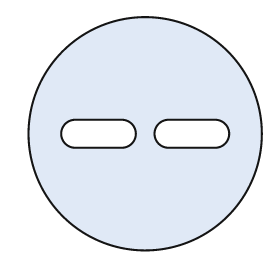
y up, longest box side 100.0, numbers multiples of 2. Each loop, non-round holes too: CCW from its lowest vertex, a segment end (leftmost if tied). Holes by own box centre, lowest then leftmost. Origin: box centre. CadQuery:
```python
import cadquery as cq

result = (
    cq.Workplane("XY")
    .moveTo(0.0, 0.0)
    .circle(50.0)
    .moveTo(-30.0, -6.0)
    .lineTo(-10.0, -6.0)
    .threePointArc((-4.0, 0.0), (-10.0, 6.0))
    .lineTo(-30.0, 6.0)
    .threePointArc((-36.0, 0.0), (-30.0, -6.0))
    .close()
    .moveTo(10.0, -6.0)
    .lineTo(30.0, -6.0)
    .threePointArc((36.0, 0.0), (30.0, 6.0))
    .lineTo(10.0, 6.0)
    .threePointArc((4.0, 0.0), (10.0, -6.0))
    .close()
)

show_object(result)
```